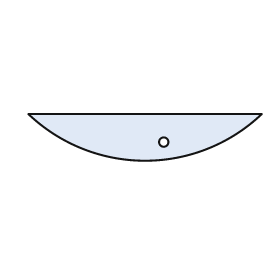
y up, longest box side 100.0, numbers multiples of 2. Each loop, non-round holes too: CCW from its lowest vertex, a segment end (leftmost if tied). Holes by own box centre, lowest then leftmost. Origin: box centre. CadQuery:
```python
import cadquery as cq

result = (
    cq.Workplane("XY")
    .moveTo(-50.0, 10.0)
    .threePointArc((0.0, -10.0), (50.0, 10.0))
    .close()
    .moveTo(8.0, -2.0)
    .circle(2.0)
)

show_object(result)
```